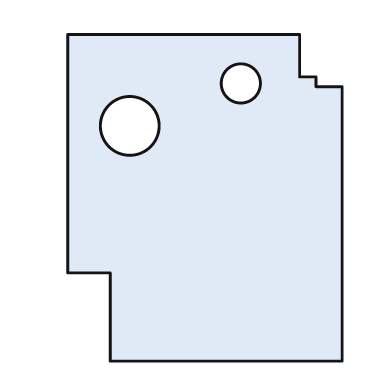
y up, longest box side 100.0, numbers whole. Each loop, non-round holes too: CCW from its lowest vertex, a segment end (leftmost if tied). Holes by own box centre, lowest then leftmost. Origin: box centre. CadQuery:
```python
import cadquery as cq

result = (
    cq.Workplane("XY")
    .moveTo(-29.0, -50.0)
    .lineTo(42.0, -50.0)
    .lineTo(42.0, 34.0)
    .lineTo(34.0, 34.0)
    .lineTo(34.0, 37.0)
    .lineTo(29.0, 37.0)
    .lineTo(29.0, 50.0)
    .lineTo(-42.0, 50.0)
    .lineTo(-42.0, -23.0)
    .lineTo(-29.0, -23.0)
    .close()
    .moveTo(-23.0, 22.0)
    .circle(9.0)
    .moveTo(11.0, 35.0)
    .circle(6.0)
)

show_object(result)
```